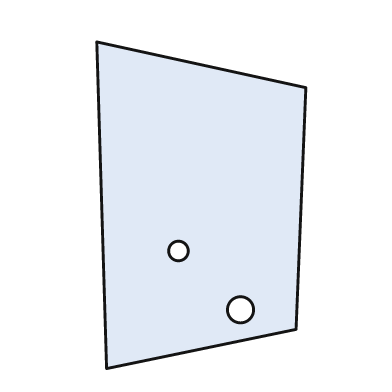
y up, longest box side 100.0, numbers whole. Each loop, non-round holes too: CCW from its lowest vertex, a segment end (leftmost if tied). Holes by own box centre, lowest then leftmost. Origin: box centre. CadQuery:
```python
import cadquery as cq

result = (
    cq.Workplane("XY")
    .moveTo(-29.0, -50.0)
    .lineTo(29.0, -38.0)
    .lineTo(32.0, 36.0)
    .lineTo(-32.0, 50.0)
    .close()
    .moveTo(12.0, -32.0)
    .circle(4.0)
    .moveTo(-7.0, -14.0)
    .circle(3.0)
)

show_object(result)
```